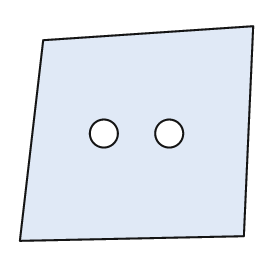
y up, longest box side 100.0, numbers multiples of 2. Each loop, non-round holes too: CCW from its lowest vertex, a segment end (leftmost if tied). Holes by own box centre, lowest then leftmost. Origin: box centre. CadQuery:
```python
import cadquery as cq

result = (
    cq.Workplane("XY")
    .moveTo(-50.0, -46.0)
    .lineTo(46.0, -44.0)
    .lineTo(50.0, 46.0)
    .lineTo(-40.0, 40.0)
    .close()
    .moveTo(-14.0, 0.0)
    .circle(6.0)
    .moveTo(14.0, 0.0)
    .circle(6.0)
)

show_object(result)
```